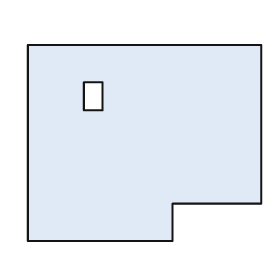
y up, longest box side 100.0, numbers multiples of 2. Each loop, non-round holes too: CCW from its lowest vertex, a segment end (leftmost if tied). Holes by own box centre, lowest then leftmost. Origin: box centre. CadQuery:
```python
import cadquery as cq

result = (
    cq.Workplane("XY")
    .moveTo(-50.0, -42.0)
    .lineTo(12.0, -42.0)
    .lineTo(12.0, -26.0)
    .lineTo(50.0, -26.0)
    .lineTo(50.0, 42.0)
    .lineTo(-50.0, 42.0)
    .close()
    .moveTo(-26.0, 14.0)
    .lineTo(-18.0, 14.0)
    .lineTo(-18.0, 26.0)
    .lineTo(-26.0, 26.0)
    .close()
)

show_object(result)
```